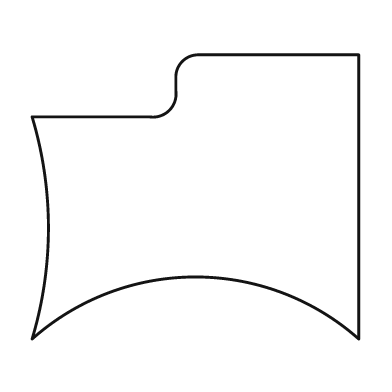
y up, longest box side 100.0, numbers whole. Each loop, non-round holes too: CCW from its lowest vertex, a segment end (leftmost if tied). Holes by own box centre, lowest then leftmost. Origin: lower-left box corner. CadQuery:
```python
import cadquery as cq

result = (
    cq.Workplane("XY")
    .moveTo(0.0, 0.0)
    .threePointArc((50.0, 19.0), (100.0, 0.0))
    .lineTo(100.0, 87.0)
    .lineTo(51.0, 87.0)
    .threePointArc((46.0, 85.0), (44.0, 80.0))
    .lineTo(44.0, 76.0)
    .threePointArc((42.0, 70.0), (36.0, 68.0))
    .lineTo(0.0, 68.0)
    .threePointArc((5.0, 34.0), (0.0, 0.0))
    .close()
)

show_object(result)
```